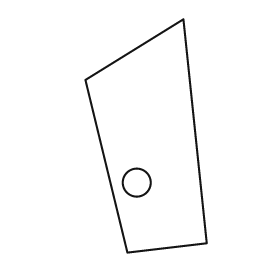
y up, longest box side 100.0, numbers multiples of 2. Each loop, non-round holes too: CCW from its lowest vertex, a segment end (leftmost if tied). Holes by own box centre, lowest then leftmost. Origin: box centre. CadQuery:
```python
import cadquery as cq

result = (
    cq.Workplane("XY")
    .moveTo(-8.0, -50.0)
    .lineTo(26.0, -46.0)
    .lineTo(16.0, 50.0)
    .lineTo(-26.0, 24.0)
    .close()
    .moveTo(-4.0, -20.0)
    .circle(6.0)
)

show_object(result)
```